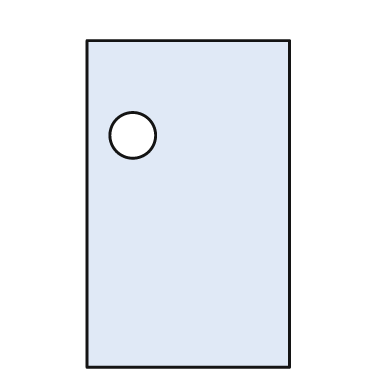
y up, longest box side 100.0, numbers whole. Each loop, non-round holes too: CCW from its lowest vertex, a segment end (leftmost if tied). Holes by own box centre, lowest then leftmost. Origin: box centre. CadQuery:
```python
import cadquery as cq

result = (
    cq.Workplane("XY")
    .moveTo(-31.0, -50.0)
    .lineTo(31.0, -50.0)
    .lineTo(31.0, 50.0)
    .lineTo(-31.0, 50.0)
    .close()
    .moveTo(-17.0, 21.0)
    .circle(7.0)
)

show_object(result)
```